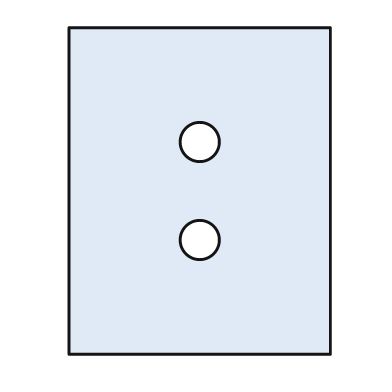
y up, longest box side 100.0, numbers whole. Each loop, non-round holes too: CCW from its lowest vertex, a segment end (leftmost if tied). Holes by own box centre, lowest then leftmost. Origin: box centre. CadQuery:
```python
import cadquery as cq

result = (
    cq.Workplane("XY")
    .moveTo(-40.0, -50.0)
    .lineTo(40.0, -50.0)
    .lineTo(40.0, 50.0)
    .lineTo(-40.0, 50.0)
    .close()
    .moveTo(0.0, -15.0)
    .circle(6.0)
    .moveTo(0.0, 15.0)
    .circle(6.0)
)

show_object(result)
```